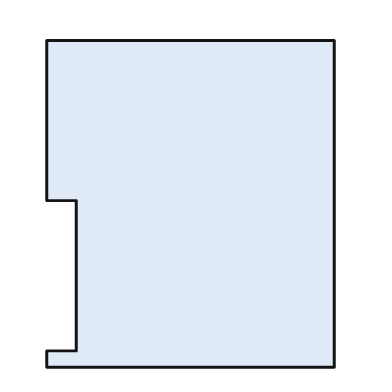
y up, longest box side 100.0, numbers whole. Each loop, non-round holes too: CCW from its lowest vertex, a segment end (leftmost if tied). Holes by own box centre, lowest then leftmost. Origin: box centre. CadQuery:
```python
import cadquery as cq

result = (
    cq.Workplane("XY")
    .moveTo(-44.0, -50.0)
    .lineTo(44.0, -50.0)
    .lineTo(44.0, 50.0)
    .lineTo(-44.0, 50.0)
    .lineTo(-44.0, 1.0)
    .lineTo(-35.0, 1.0)
    .lineTo(-35.0, -45.0)
    .lineTo(-44.0, -45.0)
    .close()
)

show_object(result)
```